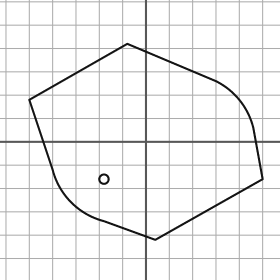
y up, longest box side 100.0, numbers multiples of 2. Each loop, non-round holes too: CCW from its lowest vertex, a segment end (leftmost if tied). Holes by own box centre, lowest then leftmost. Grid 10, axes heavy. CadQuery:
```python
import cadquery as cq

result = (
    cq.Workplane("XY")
    .moveTo(4.0, -42.0)
    .lineTo(50.0, -16.0)
    .lineTo(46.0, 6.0)
    .threePointArc((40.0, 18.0), (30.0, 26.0))
    .lineTo(-8.0, 42.0)
    .lineTo(-50.0, 18.0)
    .lineTo(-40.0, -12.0)
    .threePointArc((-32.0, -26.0), (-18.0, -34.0))
    .close()
    .moveTo(-18.0, -16.0)
    .circle(2.0)
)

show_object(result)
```